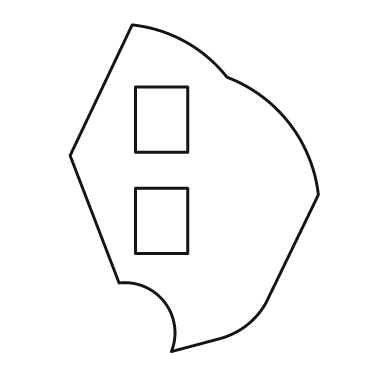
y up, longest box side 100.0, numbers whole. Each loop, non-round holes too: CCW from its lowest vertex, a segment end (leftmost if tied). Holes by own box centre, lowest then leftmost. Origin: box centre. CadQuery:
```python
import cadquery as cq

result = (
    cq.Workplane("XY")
    .moveTo(-7.0, -50.0)
    .lineTo(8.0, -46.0)
    .threePointArc((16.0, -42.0), (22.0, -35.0))
    .lineTo(38.0, -2.0)
    .threePointArc((29.0, 20.0), (10.0, 34.0))
    .threePointArc((-3.0, 45.0), (-19.0, 50.0))
    .lineTo(-38.0, 10.0)
    .lineTo(-23.0, -29.0)
    .threePointArc((-9.0, -35.0), (-7.0, -50.0))
    .close()
    .moveTo(-18.0, -20.0)
    .lineTo(-2.0, -20.0)
    .lineTo(-2.0, 0.0)
    .lineTo(-18.0, 0.0)
    .close()
    .moveTo(-18.0, 11.0)
    .lineTo(-2.0, 11.0)
    .lineTo(-2.0, 31.0)
    .lineTo(-18.0, 31.0)
    .close()
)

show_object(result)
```